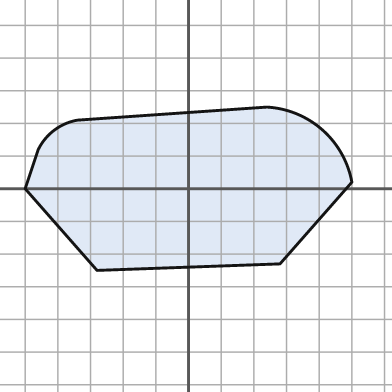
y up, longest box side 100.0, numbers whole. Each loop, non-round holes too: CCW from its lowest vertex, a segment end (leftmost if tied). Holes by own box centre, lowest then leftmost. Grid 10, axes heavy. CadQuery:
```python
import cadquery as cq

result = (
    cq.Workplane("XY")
    .moveTo(-28.0, -25.0)
    .lineTo(28.0, -23.0)
    .lineTo(50.0, 2.0)
    .threePointArc((41.0, 18.0), (24.0, 25.0))
    .lineTo(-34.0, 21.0)
    .threePointArc((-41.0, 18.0), (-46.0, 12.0))
    .lineTo(-50.0, 0.0)
    .close()
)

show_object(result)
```